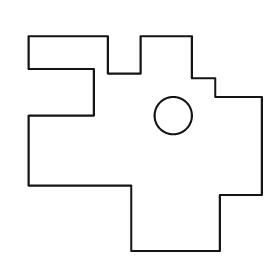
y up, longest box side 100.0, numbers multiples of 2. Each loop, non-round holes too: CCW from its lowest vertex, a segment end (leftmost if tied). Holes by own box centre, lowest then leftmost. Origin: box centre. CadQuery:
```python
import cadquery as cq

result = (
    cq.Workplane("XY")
    .moveTo(-6.0, -46.0)
    .lineTo(32.0, -46.0)
    .lineTo(32.0, -22.0)
    .lineTo(50.0, -22.0)
    .lineTo(50.0, 20.0)
    .lineTo(30.0, 20.0)
    .lineTo(30.0, 28.0)
    .lineTo(20.0, 28.0)
    .lineTo(20.0, 46.0)
    .lineTo(-2.0, 46.0)
    .lineTo(-2.0, 30.0)
    .lineTo(-16.0, 30.0)
    .lineTo(-16.0, 46.0)
    .lineTo(-50.0, 46.0)
    .lineTo(-50.0, 32.0)
    .lineTo(-22.0, 32.0)
    .lineTo(-22.0, 12.0)
    .lineTo(-50.0, 12.0)
    .lineTo(-50.0, -18.0)
    .lineTo(-6.0, -18.0)
    .close()
    .moveTo(12.0, 12.0)
    .circle(8.0)
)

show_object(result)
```